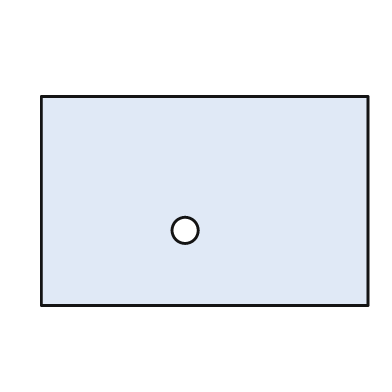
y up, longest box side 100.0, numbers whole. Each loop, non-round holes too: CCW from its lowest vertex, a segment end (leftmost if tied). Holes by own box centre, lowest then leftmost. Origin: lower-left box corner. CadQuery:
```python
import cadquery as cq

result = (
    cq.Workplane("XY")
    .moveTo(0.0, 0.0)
    .lineTo(100.0, 0.0)
    .lineTo(100.0, 64.0)
    .lineTo(0.0, 64.0)
    .close()
    .moveTo(44.0, 23.0)
    .circle(4.0)
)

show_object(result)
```